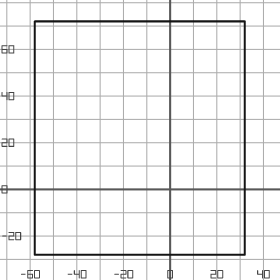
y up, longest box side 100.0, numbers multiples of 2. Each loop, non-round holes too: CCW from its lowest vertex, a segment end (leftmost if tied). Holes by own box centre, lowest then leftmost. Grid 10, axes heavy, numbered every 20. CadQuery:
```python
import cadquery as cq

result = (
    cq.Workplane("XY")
    .moveTo(-58.0, -28.0)
    .lineTo(32.0, -28.0)
    .lineTo(32.0, 72.0)
    .lineTo(-58.0, 72.0)
    .close()
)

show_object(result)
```